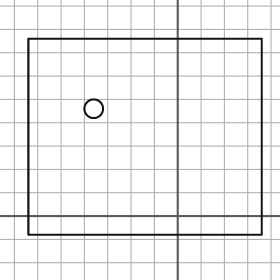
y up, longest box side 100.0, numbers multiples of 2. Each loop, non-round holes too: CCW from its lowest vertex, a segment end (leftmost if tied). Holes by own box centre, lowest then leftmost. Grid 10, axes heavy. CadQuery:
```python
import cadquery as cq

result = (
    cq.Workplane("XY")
    .moveTo(-64.0, -8.0)
    .lineTo(36.0, -8.0)
    .lineTo(36.0, 76.0)
    .lineTo(-64.0, 76.0)
    .close()
    .moveTo(-36.0, 46.0)
    .circle(4.0)
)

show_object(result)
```